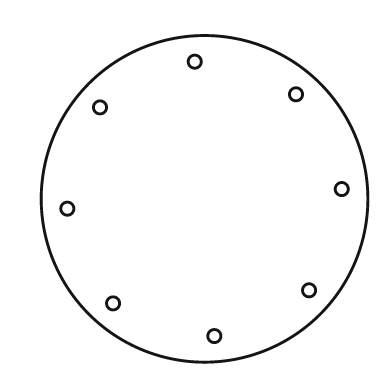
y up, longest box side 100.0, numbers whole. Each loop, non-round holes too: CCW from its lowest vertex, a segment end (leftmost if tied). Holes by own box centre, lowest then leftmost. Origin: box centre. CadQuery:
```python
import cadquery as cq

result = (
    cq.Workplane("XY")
    .moveTo(0.0, 0.0)
    .circle(50.0)
    .moveTo(3.0, -42.0)
    .circle(2.0)
    .moveTo(-28.0, -32.0)
    .circle(2.0)
    .moveTo(32.0, -28.0)
    .circle(2.0)
    .moveTo(-42.0, -3.0)
    .circle(2.0)
    .moveTo(42.0, 3.0)
    .circle(2.0)
    .moveTo(-32.0, 28.0)
    .circle(2.0)
    .moveTo(28.0, 32.0)
    .circle(2.0)
    .moveTo(-3.0, 42.0)
    .circle(2.0)
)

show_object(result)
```